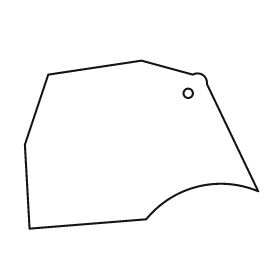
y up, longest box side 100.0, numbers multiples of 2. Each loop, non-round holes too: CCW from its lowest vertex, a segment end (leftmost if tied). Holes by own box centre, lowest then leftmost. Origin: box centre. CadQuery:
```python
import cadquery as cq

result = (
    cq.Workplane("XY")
    .moveTo(-48.0, -36.0)
    .lineTo(2.0, -32.0)
    .threePointArc((24.0, -18.0), (50.0, -20.0))
    .lineTo(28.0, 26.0)
    .threePointArc((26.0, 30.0), (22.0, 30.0))
    .lineTo(0.0, 36.0)
    .lineTo(-40.0, 30.0)
    .lineTo(-50.0, 0.0)
    .close()
    .moveTo(20.0, 22.0)
    .circle(2.0)
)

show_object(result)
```